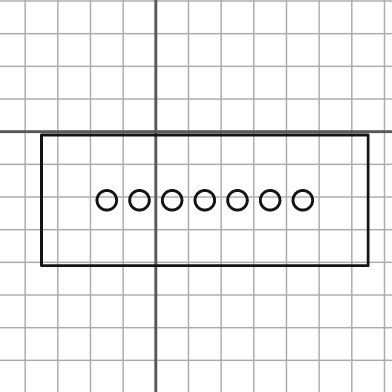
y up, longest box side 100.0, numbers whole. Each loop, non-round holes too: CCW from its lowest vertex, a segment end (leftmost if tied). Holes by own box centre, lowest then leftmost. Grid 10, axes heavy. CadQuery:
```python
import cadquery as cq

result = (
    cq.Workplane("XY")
    .moveTo(-35.0, -41.0)
    .lineTo(65.0, -41.0)
    .lineTo(65.0, -1.0)
    .lineTo(-35.0, -1.0)
    .close()
    .moveTo(-15.0, -21.0)
    .circle(3.0)
    .moveTo(-5.0, -21.0)
    .circle(3.0)
    .moveTo(5.0, -21.0)
    .circle(3.0)
    .moveTo(15.0, -21.0)
    .circle(3.0)
    .moveTo(25.0, -21.0)
    .circle(3.0)
    .moveTo(35.0, -21.0)
    .circle(3.0)
    .moveTo(45.0, -21.0)
    .circle(3.0)
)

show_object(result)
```